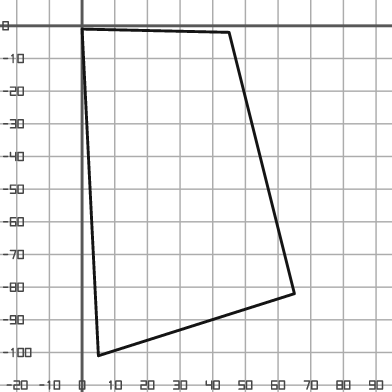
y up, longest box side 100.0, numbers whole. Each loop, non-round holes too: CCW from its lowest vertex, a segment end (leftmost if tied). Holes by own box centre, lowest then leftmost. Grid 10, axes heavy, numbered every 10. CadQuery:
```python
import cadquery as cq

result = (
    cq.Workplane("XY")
    .moveTo(5.0, -101.0)
    .lineTo(65.0, -82.0)
    .lineTo(45.0, -2.0)
    .lineTo(0.0, -1.0)
    .close()
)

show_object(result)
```